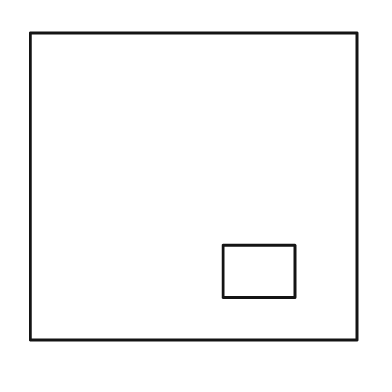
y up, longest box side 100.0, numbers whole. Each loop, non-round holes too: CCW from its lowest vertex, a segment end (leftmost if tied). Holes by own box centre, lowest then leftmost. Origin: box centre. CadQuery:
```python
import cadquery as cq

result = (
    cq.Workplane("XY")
    .moveTo(-50.0, -47.0)
    .lineTo(50.0, -47.0)
    .lineTo(50.0, 47.0)
    .lineTo(-50.0, 47.0)
    .close()
    .moveTo(9.0, -34.0)
    .lineTo(31.0, -34.0)
    .lineTo(31.0, -18.0)
    .lineTo(9.0, -18.0)
    .close()
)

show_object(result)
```